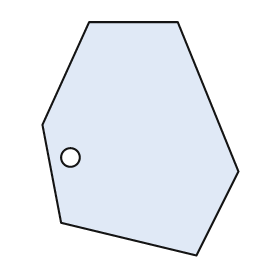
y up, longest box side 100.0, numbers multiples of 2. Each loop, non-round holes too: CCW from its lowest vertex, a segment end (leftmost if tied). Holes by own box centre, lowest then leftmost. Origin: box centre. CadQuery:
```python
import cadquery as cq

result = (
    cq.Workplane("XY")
    .moveTo(24.0, -50.0)
    .lineTo(42.0, -14.0)
    .lineTo(16.0, 50.0)
    .lineTo(-22.0, 50.0)
    .lineTo(-42.0, 6.0)
    .lineTo(-34.0, -36.0)
    .close()
    .moveTo(-30.0, -8.0)
    .circle(4.0)
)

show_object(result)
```